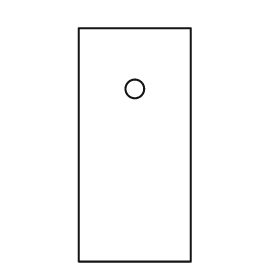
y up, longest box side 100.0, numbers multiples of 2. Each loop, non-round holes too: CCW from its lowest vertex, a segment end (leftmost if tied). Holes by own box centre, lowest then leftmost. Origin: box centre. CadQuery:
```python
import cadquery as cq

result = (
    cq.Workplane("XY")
    .moveTo(-24.0, -50.0)
    .lineTo(24.0, -50.0)
    .lineTo(24.0, 50.0)
    .lineTo(-24.0, 50.0)
    .close()
    .moveTo(0.0, 24.0)
    .circle(4.0)
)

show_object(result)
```